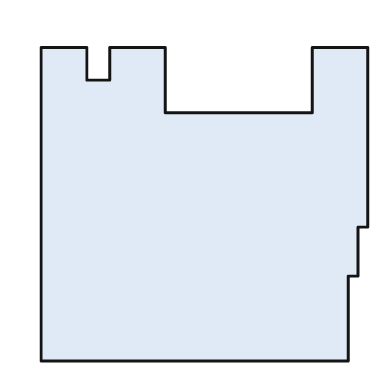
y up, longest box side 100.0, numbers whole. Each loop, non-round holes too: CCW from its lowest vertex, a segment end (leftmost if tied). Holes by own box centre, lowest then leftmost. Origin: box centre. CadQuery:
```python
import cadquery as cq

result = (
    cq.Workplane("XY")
    .moveTo(-50.0, -48.0)
    .lineTo(44.0, -48.0)
    .lineTo(44.0, -22.0)
    .lineTo(47.0, -22.0)
    .lineTo(47.0, -7.0)
    .lineTo(50.0, -7.0)
    .lineTo(50.0, 48.0)
    .lineTo(33.0, 48.0)
    .lineTo(33.0, 28.0)
    .lineTo(-12.0, 28.0)
    .lineTo(-12.0, 48.0)
    .lineTo(-29.0, 48.0)
    .lineTo(-29.0, 38.0)
    .lineTo(-36.0, 38.0)
    .lineTo(-36.0, 48.0)
    .lineTo(-50.0, 48.0)
    .close()
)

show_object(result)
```